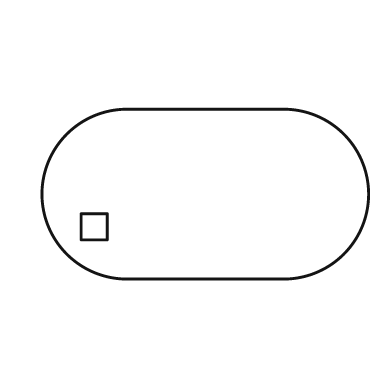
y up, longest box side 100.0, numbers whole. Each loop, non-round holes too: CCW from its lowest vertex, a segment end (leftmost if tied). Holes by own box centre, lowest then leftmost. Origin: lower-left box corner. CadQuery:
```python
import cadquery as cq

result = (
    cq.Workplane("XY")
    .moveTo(26.0, 0.0)
    .lineTo(74.0, 0.0)
    .threePointArc((100.0, 26.0), (74.0, 52.0))
    .lineTo(26.0, 52.0)
    .threePointArc((0.0, 26.0), (26.0, 0.0))
    .close()
    .moveTo(12.0, 12.0)
    .lineTo(20.0, 12.0)
    .lineTo(20.0, 20.0)
    .lineTo(12.0, 20.0)
    .close()
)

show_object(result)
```